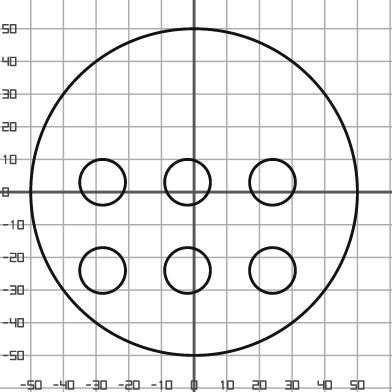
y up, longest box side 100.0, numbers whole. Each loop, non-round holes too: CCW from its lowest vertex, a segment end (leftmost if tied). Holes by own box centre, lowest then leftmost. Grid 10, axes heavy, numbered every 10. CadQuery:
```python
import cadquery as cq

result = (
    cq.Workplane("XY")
    .moveTo(0.0, 0.0)
    .circle(50.0)
    .moveTo(-28.0, -24.0)
    .circle(7.0)
    .moveTo(-2.0, -24.0)
    .circle(7.0)
    .moveTo(24.0, -24.0)
    .circle(7.0)
    .moveTo(-28.0, 3.0)
    .circle(7.0)
    .moveTo(-2.0, 3.0)
    .circle(7.0)
    .moveTo(24.0, 3.0)
    .circle(7.0)
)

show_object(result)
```